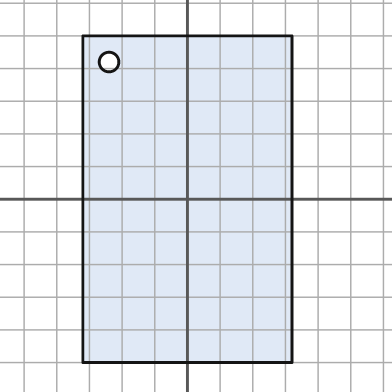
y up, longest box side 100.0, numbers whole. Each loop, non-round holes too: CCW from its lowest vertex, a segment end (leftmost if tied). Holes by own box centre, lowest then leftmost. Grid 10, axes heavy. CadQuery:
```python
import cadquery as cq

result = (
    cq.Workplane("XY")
    .moveTo(-32.0, -50.0)
    .lineTo(32.0, -50.0)
    .lineTo(32.0, 50.0)
    .lineTo(-32.0, 50.0)
    .close()
    .moveTo(-24.0, 42.0)
    .circle(3.0)
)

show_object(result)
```